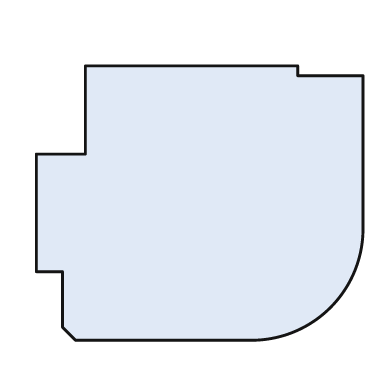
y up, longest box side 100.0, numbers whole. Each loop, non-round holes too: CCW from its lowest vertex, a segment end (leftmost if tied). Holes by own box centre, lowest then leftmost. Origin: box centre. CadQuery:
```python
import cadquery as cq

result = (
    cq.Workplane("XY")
    .moveTo(-38.0, -42.0)
    .lineTo(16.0, -42.0)
    .threePointArc((40.0, -32.0), (50.0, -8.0))
    .lineTo(50.0, 39.0)
    .lineTo(30.0, 39.0)
    .lineTo(30.0, 42.0)
    .lineTo(-35.0, 42.0)
    .lineTo(-35.0, 15.0)
    .lineTo(-50.0, 15.0)
    .lineTo(-50.0, -21.0)
    .lineTo(-42.0, -21.0)
    .lineTo(-42.0, -38.0)
    .close()
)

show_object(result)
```